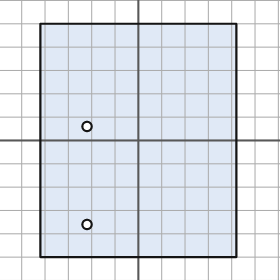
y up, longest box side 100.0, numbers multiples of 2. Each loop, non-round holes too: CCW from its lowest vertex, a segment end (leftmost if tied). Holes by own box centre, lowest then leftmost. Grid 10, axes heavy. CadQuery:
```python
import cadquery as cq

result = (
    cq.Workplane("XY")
    .moveTo(-42.0, -50.0)
    .lineTo(42.0, -50.0)
    .lineTo(42.0, 50.0)
    .lineTo(-42.0, 50.0)
    .close()
    .moveTo(-22.0, -36.0)
    .circle(2.0)
    .moveTo(-22.0, 6.0)
    .circle(2.0)
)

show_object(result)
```